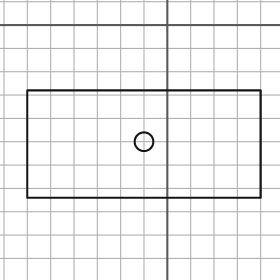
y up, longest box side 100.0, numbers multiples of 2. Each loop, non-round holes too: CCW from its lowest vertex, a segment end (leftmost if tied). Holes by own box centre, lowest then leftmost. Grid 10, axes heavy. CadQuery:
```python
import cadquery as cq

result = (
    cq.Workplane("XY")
    .moveTo(-60.0, -74.0)
    .lineTo(40.0, -74.0)
    .lineTo(40.0, -28.0)
    .lineTo(-60.0, -28.0)
    .close()
    .moveTo(-10.0, -50.0)
    .circle(4.0)
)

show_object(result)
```